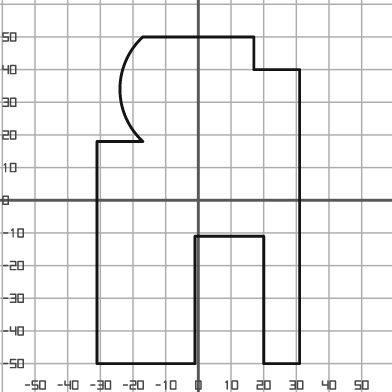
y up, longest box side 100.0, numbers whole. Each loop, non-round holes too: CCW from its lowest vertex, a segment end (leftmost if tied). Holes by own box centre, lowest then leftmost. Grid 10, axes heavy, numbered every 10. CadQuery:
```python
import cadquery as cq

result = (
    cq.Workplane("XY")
    .moveTo(-31.0, -50.0)
    .lineTo(-1.0, -50.0)
    .lineTo(-1.0, -11.0)
    .lineTo(20.0, -11.0)
    .lineTo(20.0, -50.0)
    .lineTo(31.0, -50.0)
    .lineTo(31.0, 40.0)
    .lineTo(17.0, 40.0)
    .lineTo(17.0, 50.0)
    .lineTo(-17.0, 50.0)
    .threePointArc((-24.0, 34.0), (-17.0, 18.0))
    .lineTo(-31.0, 18.0)
    .close()
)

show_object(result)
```